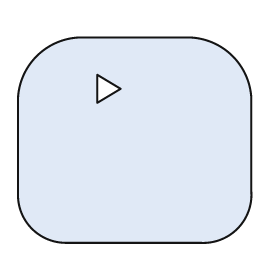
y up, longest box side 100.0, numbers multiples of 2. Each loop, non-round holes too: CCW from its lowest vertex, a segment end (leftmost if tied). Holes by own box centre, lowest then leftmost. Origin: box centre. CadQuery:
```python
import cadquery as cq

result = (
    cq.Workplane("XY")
    .moveTo(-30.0, -44.0)
    .lineTo(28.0, -44.0)
    .threePointArc((44.0, -38.0), (50.0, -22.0))
    .lineTo(50.0, 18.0)
    .threePointArc((42.0, 36.0), (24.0, 44.0))
    .lineTo(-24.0, 44.0)
    .threePointArc((-42.0, 36.0), (-50.0, 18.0))
    .lineTo(-50.0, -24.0)
    .threePointArc((-44.0, -38.0), (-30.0, -44.0))
    .close()
    .moveTo(-16.0, 16.0)
    .lineTo(-6.0, 22.0)
    .lineTo(-16.0, 28.0)
    .close()
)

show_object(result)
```